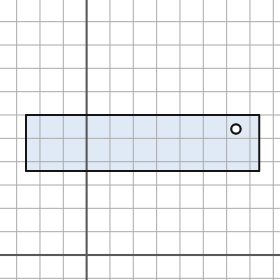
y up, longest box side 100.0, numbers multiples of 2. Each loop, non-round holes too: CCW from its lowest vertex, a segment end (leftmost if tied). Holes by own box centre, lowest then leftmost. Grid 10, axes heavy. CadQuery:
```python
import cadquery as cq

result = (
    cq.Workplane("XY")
    .moveTo(-26.0, 36.0)
    .lineTo(74.0, 36.0)
    .lineTo(74.0, 60.0)
    .lineTo(-26.0, 60.0)
    .close()
    .moveTo(64.0, 54.0)
    .circle(2.0)
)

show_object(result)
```